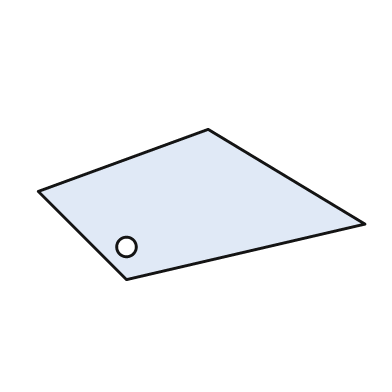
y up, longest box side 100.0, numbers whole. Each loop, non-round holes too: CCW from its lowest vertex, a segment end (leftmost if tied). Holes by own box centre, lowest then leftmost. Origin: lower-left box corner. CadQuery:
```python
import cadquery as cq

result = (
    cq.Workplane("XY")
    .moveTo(27.0, 0.0)
    .lineTo(100.0, 17.0)
    .lineTo(52.0, 46.0)
    .lineTo(0.0, 27.0)
    .close()
    .moveTo(27.0, 10.0)
    .circle(3.0)
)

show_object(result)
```